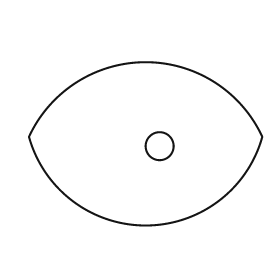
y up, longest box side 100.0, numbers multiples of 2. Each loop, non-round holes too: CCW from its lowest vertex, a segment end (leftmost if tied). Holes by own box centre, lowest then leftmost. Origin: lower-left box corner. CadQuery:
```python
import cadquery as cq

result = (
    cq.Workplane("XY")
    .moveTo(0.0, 38.0)
    .threePointArc((50.0, 0.0), (100.0, 38.0))
    .threePointArc((50.0, 70.0), (0.0, 38.0))
    .close()
    .moveTo(56.0, 34.0)
    .circle(6.0)
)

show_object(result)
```